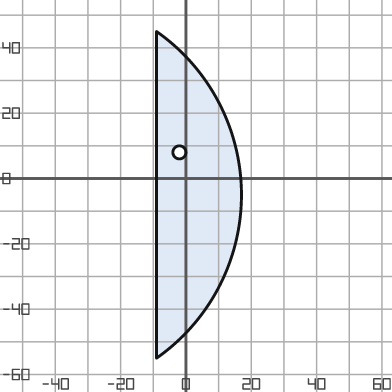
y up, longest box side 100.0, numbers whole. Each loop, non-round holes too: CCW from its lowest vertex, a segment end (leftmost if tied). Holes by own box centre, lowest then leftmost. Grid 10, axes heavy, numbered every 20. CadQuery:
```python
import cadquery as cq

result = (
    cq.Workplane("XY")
    .moveTo(-9.0, -55.0)
    .threePointArc((17.0, -5.0), (-9.0, 45.0))
    .close()
    .moveTo(-2.0, 8.0)
    .circle(2.0)
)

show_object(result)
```